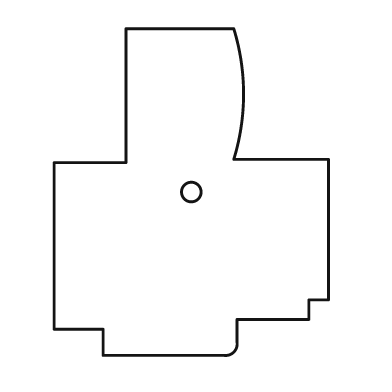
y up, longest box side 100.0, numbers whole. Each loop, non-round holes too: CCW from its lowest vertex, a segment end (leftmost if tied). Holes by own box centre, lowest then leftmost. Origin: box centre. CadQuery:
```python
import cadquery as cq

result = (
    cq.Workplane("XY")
    .moveTo(-27.0, -50.0)
    .lineTo(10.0, -50.0)
    .threePointArc((13.0, -49.0), (14.0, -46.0))
    .lineTo(14.0, -39.0)
    .lineTo(36.0, -39.0)
    .lineTo(36.0, -33.0)
    .lineTo(42.0, -33.0)
    .lineTo(42.0, 10.0)
    .lineTo(13.0, 10.0)
    .threePointArc((16.0, 30.0), (13.0, 50.0))
    .lineTo(-20.0, 50.0)
    .lineTo(-20.0, 9.0)
    .lineTo(-42.0, 9.0)
    .lineTo(-42.0, -42.0)
    .lineTo(-27.0, -42.0)
    .close()
    .moveTo(0.0, 0.0)
    .circle(3.0)
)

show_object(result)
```